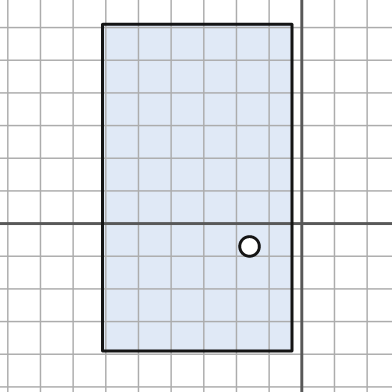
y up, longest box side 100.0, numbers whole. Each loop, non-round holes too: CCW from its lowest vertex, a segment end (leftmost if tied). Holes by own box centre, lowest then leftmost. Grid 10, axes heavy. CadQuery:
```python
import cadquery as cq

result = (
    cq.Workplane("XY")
    .moveTo(-61.0, -39.0)
    .lineTo(-3.0, -39.0)
    .lineTo(-3.0, 61.0)
    .lineTo(-61.0, 61.0)
    .close()
    .moveTo(-16.0, -7.0)
    .circle(3.0)
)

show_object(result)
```